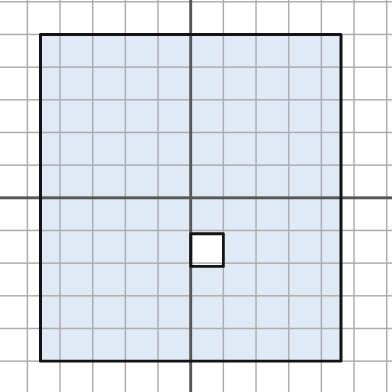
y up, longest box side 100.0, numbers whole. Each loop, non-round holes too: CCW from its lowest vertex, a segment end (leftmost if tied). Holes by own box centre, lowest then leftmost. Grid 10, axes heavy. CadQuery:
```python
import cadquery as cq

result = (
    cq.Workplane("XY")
    .moveTo(-46.0, -50.0)
    .lineTo(46.0, -50.0)
    .lineTo(46.0, 50.0)
    .lineTo(-46.0, 50.0)
    .close()
    .moveTo(0.0, -21.0)
    .lineTo(10.0, -21.0)
    .lineTo(10.0, -11.0)
    .lineTo(0.0, -11.0)
    .close()
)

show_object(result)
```